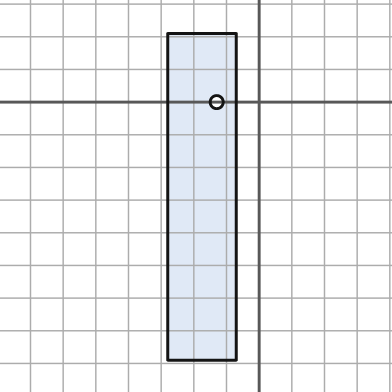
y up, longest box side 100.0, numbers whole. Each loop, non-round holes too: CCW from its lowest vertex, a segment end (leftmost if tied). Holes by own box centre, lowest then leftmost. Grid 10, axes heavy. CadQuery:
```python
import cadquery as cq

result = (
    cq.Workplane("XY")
    .moveTo(-28.0, -79.0)
    .lineTo(-7.0, -79.0)
    .lineTo(-7.0, 21.0)
    .lineTo(-28.0, 21.0)
    .close()
    .moveTo(-13.0, 0.0)
    .circle(2.0)
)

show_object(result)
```